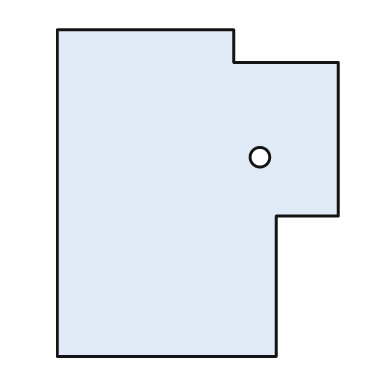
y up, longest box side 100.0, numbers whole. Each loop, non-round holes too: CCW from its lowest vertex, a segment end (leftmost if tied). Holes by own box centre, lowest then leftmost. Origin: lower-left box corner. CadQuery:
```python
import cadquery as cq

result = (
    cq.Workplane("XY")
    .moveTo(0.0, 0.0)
    .lineTo(67.0, 0.0)
    .lineTo(67.0, 43.0)
    .lineTo(86.0, 43.0)
    .lineTo(86.0, 90.0)
    .lineTo(54.0, 90.0)
    .lineTo(54.0, 100.0)
    .lineTo(0.0, 100.0)
    .close()
    .moveTo(62.0, 61.0)
    .circle(3.0)
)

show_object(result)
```